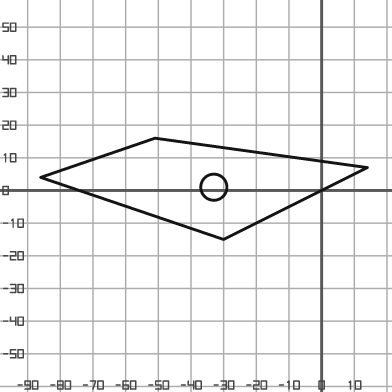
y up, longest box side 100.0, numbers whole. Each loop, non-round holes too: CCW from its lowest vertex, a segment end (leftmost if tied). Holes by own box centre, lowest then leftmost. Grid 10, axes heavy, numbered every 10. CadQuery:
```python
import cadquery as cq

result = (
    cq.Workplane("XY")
    .moveTo(-30.0, -15.0)
    .lineTo(14.0, 7.0)
    .lineTo(-51.0, 16.0)
    .lineTo(-86.0, 4.0)
    .close()
    .moveTo(-33.0, 1.0)
    .circle(4.0)
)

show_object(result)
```